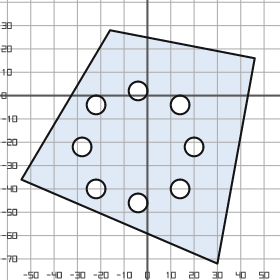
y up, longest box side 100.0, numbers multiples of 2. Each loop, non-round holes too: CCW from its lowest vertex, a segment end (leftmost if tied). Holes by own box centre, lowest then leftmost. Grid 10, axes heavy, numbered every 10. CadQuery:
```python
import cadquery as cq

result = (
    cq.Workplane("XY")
    .moveTo(30.0, -72.0)
    .lineTo(46.0, 16.0)
    .lineTo(-16.0, 28.0)
    .lineTo(-54.0, -36.0)
    .close()
    .moveTo(-4.0, -46.0)
    .circle(4.0)
    .moveTo(-22.0, -40.0)
    .circle(4.0)
    .moveTo(14.0, -40.0)
    .circle(4.0)
    .moveTo(-28.0, -22.0)
    .circle(4.0)
    .moveTo(20.0, -22.0)
    .circle(4.0)
    .moveTo(-22.0, -4.0)
    .circle(4.0)
    .moveTo(14.0, -4.0)
    .circle(4.0)
    .moveTo(-4.0, 2.0)
    .circle(4.0)
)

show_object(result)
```